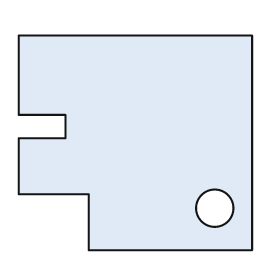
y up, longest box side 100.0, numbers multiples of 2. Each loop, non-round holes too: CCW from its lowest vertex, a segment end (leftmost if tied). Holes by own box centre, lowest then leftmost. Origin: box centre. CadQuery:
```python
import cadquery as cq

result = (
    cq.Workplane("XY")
    .moveTo(-20.0, -46.0)
    .lineTo(50.0, -46.0)
    .lineTo(50.0, 46.0)
    .lineTo(-50.0, 46.0)
    .lineTo(-50.0, 12.0)
    .lineTo(-30.0, 12.0)
    .lineTo(-30.0, 2.0)
    .lineTo(-50.0, 2.0)
    .lineTo(-50.0, -22.0)
    .lineTo(-20.0, -22.0)
    .close()
    .moveTo(34.0, -28.0)
    .circle(8.0)
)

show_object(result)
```